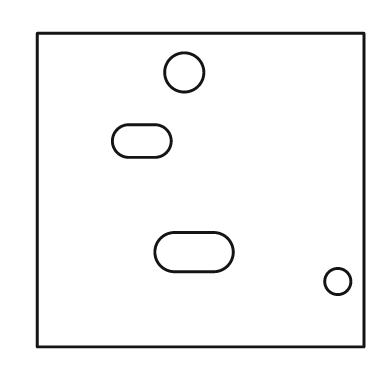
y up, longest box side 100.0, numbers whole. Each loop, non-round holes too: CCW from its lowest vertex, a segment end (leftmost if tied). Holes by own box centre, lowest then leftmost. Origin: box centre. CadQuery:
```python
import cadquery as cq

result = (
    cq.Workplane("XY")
    .moveTo(-50.0, -48.0)
    .lineTo(50.0, -48.0)
    .lineTo(50.0, 48.0)
    .lineTo(-50.0, 48.0)
    .close()
    .moveTo(42.0, -28.0)
    .circle(4.0)
    .moveTo(-8.0, -25.0)
    .lineTo(4.0, -25.0)
    .threePointArc((10.0, -19.0), (4.0, -13.0))
    .lineTo(-8.0, -13.0)
    .threePointArc((-14.0, -19.0), (-8.0, -25.0))
    .close()
    .moveTo(-22.0, 10.0)
    .lineTo(-14.0, 10.0)
    .threePointArc((-9.0, 15.0), (-14.0, 20.0))
    .lineTo(-22.0, 20.0)
    .threePointArc((-27.0, 15.0), (-22.0, 10.0))
    .close()
    .moveTo(-5.0, 36.0)
    .circle(6.0)
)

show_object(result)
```